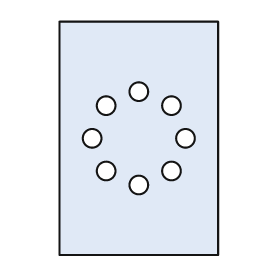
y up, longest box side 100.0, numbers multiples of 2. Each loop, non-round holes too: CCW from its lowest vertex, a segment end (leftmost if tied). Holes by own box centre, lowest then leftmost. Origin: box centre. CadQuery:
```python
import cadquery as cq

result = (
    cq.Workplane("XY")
    .moveTo(-34.0, -50.0)
    .lineTo(34.0, -50.0)
    .lineTo(34.0, 50.0)
    .lineTo(-34.0, 50.0)
    .close()
    .moveTo(0.0, -20.0)
    .circle(4.0)
    .moveTo(-14.0, -14.0)
    .circle(4.0)
    .moveTo(14.0, -14.0)
    .circle(4.0)
    .moveTo(-20.0, 0.0)
    .circle(4.0)
    .moveTo(20.0, 0.0)
    .circle(4.0)
    .moveTo(-14.0, 14.0)
    .circle(4.0)
    .moveTo(14.0, 14.0)
    .circle(4.0)
    .moveTo(0.0, 20.0)
    .circle(4.0)
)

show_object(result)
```